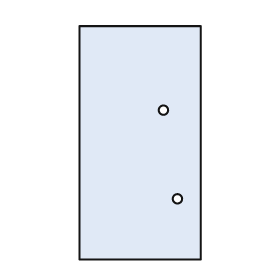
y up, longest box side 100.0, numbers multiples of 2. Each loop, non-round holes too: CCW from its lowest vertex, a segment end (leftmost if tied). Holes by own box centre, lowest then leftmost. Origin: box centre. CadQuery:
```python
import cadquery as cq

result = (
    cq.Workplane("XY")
    .moveTo(-26.0, -50.0)
    .lineTo(26.0, -50.0)
    .lineTo(26.0, 50.0)
    .lineTo(-26.0, 50.0)
    .close()
    .moveTo(16.0, -24.0)
    .circle(2.0)
    .moveTo(10.0, 14.0)
    .circle(2.0)
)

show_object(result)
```